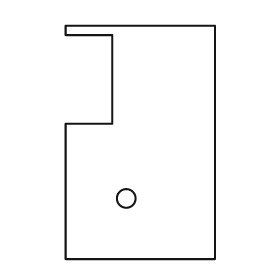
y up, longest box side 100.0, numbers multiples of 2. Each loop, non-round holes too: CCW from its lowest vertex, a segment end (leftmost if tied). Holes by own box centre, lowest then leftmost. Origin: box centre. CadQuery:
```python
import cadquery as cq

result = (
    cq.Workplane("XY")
    .moveTo(-32.0, -50.0)
    .lineTo(32.0, -50.0)
    .lineTo(32.0, 50.0)
    .lineTo(-32.0, 50.0)
    .lineTo(-32.0, 46.0)
    .lineTo(-12.0, 46.0)
    .lineTo(-12.0, 8.0)
    .lineTo(-32.0, 8.0)
    .close()
    .moveTo(-6.0, -24.0)
    .circle(4.0)
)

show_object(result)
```